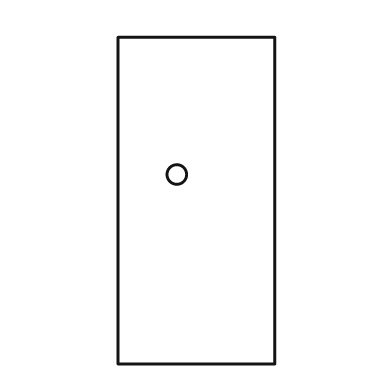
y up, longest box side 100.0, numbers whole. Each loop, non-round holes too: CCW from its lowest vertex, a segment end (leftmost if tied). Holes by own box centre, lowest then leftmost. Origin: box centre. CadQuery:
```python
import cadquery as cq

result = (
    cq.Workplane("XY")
    .moveTo(-24.0, -50.0)
    .lineTo(24.0, -50.0)
    .lineTo(24.0, 50.0)
    .lineTo(-24.0, 50.0)
    .close()
    .moveTo(-6.0, 8.0)
    .circle(3.0)
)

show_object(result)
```